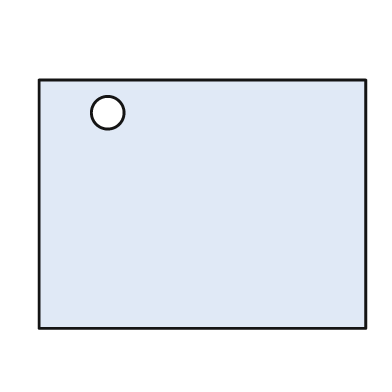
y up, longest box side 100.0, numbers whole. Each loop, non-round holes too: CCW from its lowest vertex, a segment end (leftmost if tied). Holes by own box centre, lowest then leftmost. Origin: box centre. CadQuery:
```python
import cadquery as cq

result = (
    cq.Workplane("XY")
    .moveTo(-50.0, -38.0)
    .lineTo(50.0, -38.0)
    .lineTo(50.0, 38.0)
    .lineTo(-50.0, 38.0)
    .close()
    .moveTo(-29.0, 28.0)
    .circle(5.0)
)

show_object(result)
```